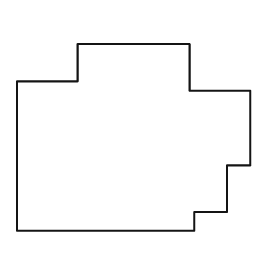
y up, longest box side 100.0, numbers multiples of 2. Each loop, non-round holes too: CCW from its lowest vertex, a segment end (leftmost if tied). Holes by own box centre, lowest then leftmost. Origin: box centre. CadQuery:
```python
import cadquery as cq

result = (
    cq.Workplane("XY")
    .moveTo(-50.0, -40.0)
    .lineTo(26.0, -40.0)
    .lineTo(26.0, -32.0)
    .lineTo(40.0, -32.0)
    .lineTo(40.0, -12.0)
    .lineTo(50.0, -12.0)
    .lineTo(50.0, 20.0)
    .lineTo(24.0, 20.0)
    .lineTo(24.0, 40.0)
    .lineTo(-24.0, 40.0)
    .lineTo(-24.0, 24.0)
    .lineTo(-50.0, 24.0)
    .close()
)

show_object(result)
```